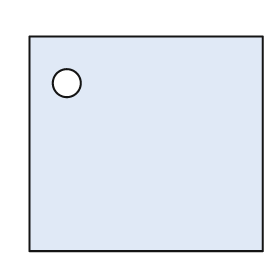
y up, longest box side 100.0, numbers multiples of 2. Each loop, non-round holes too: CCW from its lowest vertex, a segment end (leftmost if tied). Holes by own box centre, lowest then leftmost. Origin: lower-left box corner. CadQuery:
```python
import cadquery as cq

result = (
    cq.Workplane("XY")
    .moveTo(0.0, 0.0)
    .lineTo(100.0, 0.0)
    .lineTo(100.0, 92.0)
    .lineTo(0.0, 92.0)
    .close()
    .moveTo(16.0, 72.0)
    .circle(6.0)
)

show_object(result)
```